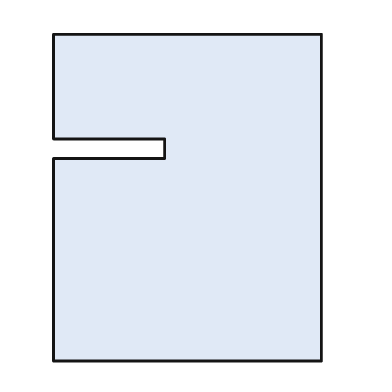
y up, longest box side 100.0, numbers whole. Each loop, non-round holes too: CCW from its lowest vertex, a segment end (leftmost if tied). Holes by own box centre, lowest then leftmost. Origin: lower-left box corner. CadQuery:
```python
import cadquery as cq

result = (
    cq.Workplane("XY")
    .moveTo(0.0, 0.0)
    .lineTo(82.0, 0.0)
    .lineTo(82.0, 100.0)
    .lineTo(0.0, 100.0)
    .lineTo(0.0, 68.0)
    .lineTo(34.0, 68.0)
    .lineTo(34.0, 62.0)
    .lineTo(0.0, 62.0)
    .close()
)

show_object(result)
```